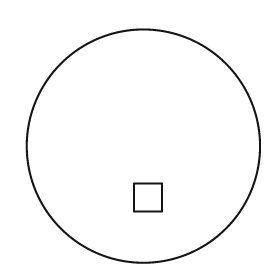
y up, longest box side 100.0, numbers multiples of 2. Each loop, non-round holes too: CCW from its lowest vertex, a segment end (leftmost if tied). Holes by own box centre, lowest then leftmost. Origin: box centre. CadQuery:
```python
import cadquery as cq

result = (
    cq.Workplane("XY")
    .moveTo(0.0, 0.0)
    .circle(50.0)
    .moveTo(-4.0, -28.0)
    .lineTo(8.0, -28.0)
    .lineTo(8.0, -16.0)
    .lineTo(-4.0, -16.0)
    .close()
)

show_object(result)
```